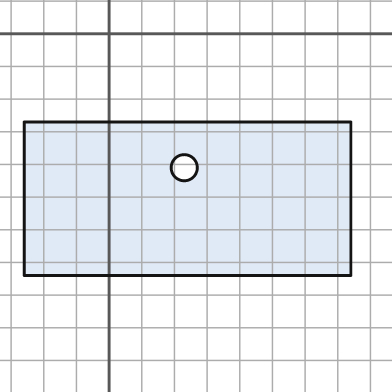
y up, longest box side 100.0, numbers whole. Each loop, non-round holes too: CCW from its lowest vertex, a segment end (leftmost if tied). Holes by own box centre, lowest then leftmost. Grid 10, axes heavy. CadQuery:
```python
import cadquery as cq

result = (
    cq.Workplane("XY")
    .moveTo(-26.0, -74.0)
    .lineTo(74.0, -74.0)
    .lineTo(74.0, -27.0)
    .lineTo(-26.0, -27.0)
    .close()
    .moveTo(23.0, -41.0)
    .circle(4.0)
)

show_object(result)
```